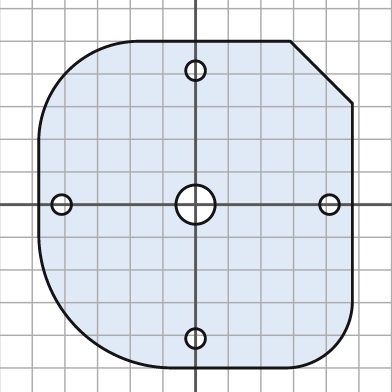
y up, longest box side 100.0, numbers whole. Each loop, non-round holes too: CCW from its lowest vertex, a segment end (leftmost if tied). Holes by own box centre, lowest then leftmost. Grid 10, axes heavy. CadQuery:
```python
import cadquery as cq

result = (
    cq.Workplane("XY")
    .moveTo(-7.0, -50.0)
    .lineTo(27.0, -50.0)
    .threePointArc((42.0, -44.0), (48.0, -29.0))
    .lineTo(48.0, 31.0)
    .lineTo(29.0, 50.0)
    .lineTo(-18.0, 50.0)
    .threePointArc((-39.0, 41.0), (-48.0, 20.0))
    .lineTo(-48.0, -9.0)
    .threePointArc((-36.0, -38.0), (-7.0, -50.0))
    .close()
    .moveTo(0.0, -41.0)
    .circle(3.0)
    .moveTo(-41.0, 0.0)
    .circle(3.0)
    .moveTo(0.0, 0.0)
    .circle(6.0)
    .moveTo(41.0, 0.0)
    .circle(3.0)
    .moveTo(0.0, 41.0)
    .circle(3.0)
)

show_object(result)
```